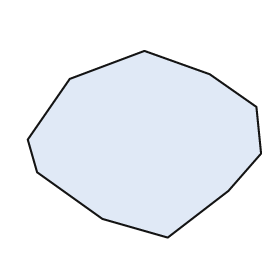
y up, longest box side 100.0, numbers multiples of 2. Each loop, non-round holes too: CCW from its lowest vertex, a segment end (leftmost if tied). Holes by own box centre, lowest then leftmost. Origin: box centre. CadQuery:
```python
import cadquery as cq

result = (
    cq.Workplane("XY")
    .moveTo(10.0, -40.0)
    .lineTo(36.0, -20.0)
    .lineTo(50.0, -4.0)
    .lineTo(48.0, 16.0)
    .lineTo(28.0, 30.0)
    .lineTo(0.0, 40.0)
    .lineTo(-32.0, 28.0)
    .lineTo(-50.0, 2.0)
    .lineTo(-46.0, -12.0)
    .lineTo(-18.0, -32.0)
    .close()
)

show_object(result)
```